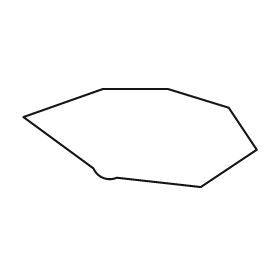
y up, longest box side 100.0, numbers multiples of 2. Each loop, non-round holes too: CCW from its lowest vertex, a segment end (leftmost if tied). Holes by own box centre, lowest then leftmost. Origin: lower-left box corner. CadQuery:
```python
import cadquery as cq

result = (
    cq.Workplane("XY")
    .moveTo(76.0, 0.0)
    .lineTo(100.0, 16.0)
    .lineTo(88.0, 34.0)
    .lineTo(62.0, 42.0)
    .lineTo(34.0, 42.0)
    .lineTo(0.0, 30.0)
    .lineTo(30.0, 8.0)
    .threePointArc((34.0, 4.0), (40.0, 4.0))
    .close()
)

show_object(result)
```